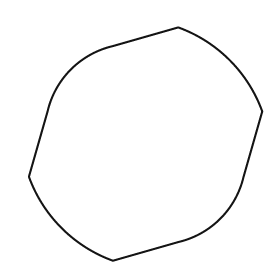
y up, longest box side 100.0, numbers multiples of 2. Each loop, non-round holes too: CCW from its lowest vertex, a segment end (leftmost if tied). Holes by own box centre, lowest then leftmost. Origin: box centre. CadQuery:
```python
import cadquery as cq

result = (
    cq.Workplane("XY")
    .moveTo(-14.0, -50.0)
    .lineTo(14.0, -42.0)
    .threePointArc((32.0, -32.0), (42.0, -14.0))
    .lineTo(50.0, 14.0)
    .threePointArc((36.0, 36.0), (14.0, 50.0))
    .lineTo(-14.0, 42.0)
    .threePointArc((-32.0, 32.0), (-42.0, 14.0))
    .lineTo(-50.0, -14.0)
    .threePointArc((-36.0, -36.0), (-14.0, -50.0))
    .close()
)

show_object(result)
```